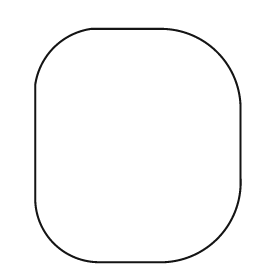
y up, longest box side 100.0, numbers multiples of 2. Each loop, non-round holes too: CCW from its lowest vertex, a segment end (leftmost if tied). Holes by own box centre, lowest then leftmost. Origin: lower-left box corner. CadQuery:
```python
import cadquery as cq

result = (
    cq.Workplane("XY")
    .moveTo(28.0, 0.0)
    .lineTo(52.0, 0.0)
    .threePointArc((78.0, 10.0), (88.0, 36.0))
    .lineTo(88.0, 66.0)
    .threePointArc((78.0, 90.0), (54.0, 100.0))
    .lineTo(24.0, 100.0)
    .threePointArc((8.0, 92.0), (0.0, 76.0))
    .lineTo(0.0, 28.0)
    .threePointArc((8.0, 8.0), (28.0, 0.0))
    .close()
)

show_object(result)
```